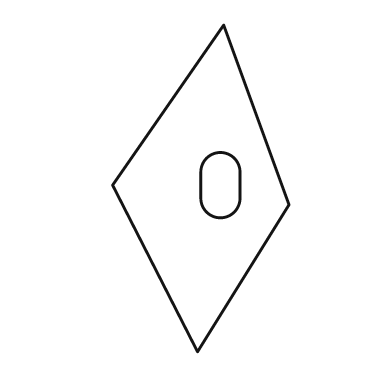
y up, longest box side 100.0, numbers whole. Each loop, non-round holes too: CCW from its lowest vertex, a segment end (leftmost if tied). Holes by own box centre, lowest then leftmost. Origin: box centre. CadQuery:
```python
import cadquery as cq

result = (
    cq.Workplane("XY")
    .moveTo(-1.0, -50.0)
    .lineTo(27.0, -5.0)
    .lineTo(7.0, 50.0)
    .lineTo(-27.0, 1.0)
    .close()
    .moveTo(0.0, -3.0)
    .threePointArc((6.0, -9.0), (12.0, -3.0))
    .lineTo(12.0, 5.0)
    .threePointArc((6.0, 11.0), (0.0, 5.0))
    .close()
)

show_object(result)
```